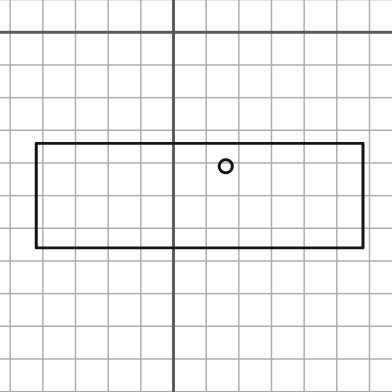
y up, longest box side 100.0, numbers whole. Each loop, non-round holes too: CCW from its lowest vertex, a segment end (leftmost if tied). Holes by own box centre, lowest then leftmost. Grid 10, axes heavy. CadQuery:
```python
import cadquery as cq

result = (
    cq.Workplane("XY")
    .moveTo(-42.0, -66.0)
    .lineTo(58.0, -66.0)
    .lineTo(58.0, -34.0)
    .lineTo(-42.0, -34.0)
    .close()
    .moveTo(16.0, -41.0)
    .circle(2.0)
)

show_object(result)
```